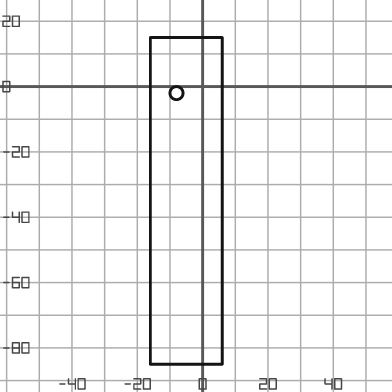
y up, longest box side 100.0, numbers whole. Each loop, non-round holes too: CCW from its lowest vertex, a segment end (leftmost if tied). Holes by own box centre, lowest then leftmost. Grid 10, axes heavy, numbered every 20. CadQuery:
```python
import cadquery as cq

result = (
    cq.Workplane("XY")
    .moveTo(-16.0, -85.0)
    .lineTo(6.0, -85.0)
    .lineTo(6.0, 15.0)
    .lineTo(-16.0, 15.0)
    .close()
    .moveTo(-8.0, -2.0)
    .circle(2.0)
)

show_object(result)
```